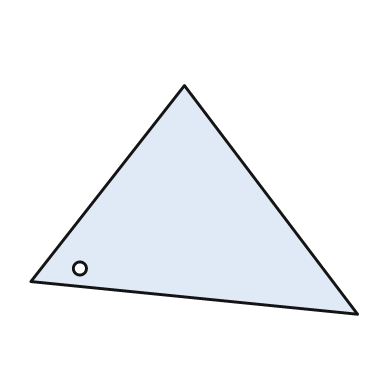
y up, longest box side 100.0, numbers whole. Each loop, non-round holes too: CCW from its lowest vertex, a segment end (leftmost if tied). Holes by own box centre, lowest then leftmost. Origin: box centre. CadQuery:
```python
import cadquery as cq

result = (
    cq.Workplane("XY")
    .moveTo(50.0, -35.0)
    .lineTo(-3.0, 35.0)
    .lineTo(-50.0, -25.0)
    .close()
    .moveTo(-35.0, -21.0)
    .circle(2.0)
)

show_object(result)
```